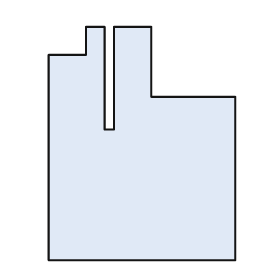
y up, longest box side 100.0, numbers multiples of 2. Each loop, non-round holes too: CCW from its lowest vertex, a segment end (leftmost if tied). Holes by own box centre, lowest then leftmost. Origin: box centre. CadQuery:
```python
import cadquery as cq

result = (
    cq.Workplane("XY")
    .moveTo(-40.0, -50.0)
    .lineTo(40.0, -50.0)
    .lineTo(40.0, 20.0)
    .lineTo(4.0, 20.0)
    .lineTo(4.0, 50.0)
    .lineTo(-12.0, 50.0)
    .lineTo(-12.0, 6.0)
    .lineTo(-16.0, 6.0)
    .lineTo(-16.0, 50.0)
    .lineTo(-24.0, 50.0)
    .lineTo(-24.0, 38.0)
    .lineTo(-40.0, 38.0)
    .close()
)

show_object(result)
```